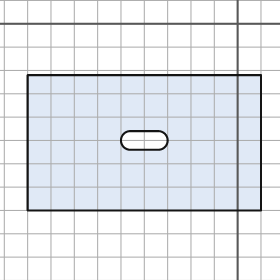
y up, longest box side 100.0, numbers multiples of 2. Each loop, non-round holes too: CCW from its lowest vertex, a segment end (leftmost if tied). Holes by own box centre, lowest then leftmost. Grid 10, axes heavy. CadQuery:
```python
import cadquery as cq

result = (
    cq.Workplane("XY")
    .moveTo(-90.0, -80.0)
    .lineTo(10.0, -80.0)
    .lineTo(10.0, -22.0)
    .lineTo(-90.0, -22.0)
    .close()
    .moveTo(-46.0, -54.0)
    .lineTo(-34.0, -54.0)
    .threePointArc((-30.0, -50.0), (-34.0, -46.0))
    .lineTo(-46.0, -46.0)
    .threePointArc((-50.0, -50.0), (-46.0, -54.0))
    .close()
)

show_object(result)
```